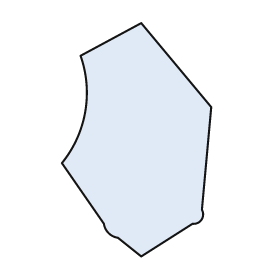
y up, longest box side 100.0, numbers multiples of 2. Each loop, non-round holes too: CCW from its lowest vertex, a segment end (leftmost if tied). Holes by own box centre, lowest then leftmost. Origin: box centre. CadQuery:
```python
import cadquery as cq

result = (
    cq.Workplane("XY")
    .moveTo(2.0, -50.0)
    .lineTo(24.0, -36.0)
    .threePointArc((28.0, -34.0), (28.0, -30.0))
    .lineTo(32.0, 14.0)
    .lineTo(2.0, 50.0)
    .lineTo(-24.0, 36.0)
    .threePointArc((-22.0, 12.0), (-32.0, -10.0))
    .lineTo(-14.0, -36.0)
    .threePointArc((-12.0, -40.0), (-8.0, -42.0))
    .close()
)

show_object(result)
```